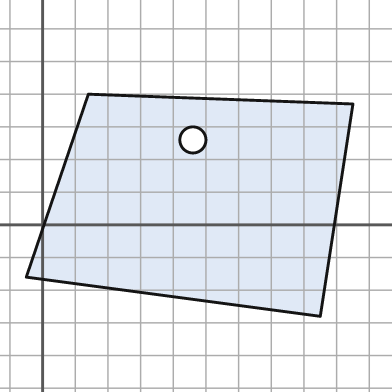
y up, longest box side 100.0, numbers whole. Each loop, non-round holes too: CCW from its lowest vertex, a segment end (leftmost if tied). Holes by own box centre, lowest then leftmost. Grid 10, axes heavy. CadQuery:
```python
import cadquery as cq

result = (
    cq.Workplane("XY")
    .moveTo(85.0, -28.0)
    .lineTo(95.0, 37.0)
    .lineTo(14.0, 40.0)
    .lineTo(-5.0, -16.0)
    .close()
    .moveTo(46.0, 26.0)
    .circle(4.0)
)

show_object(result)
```